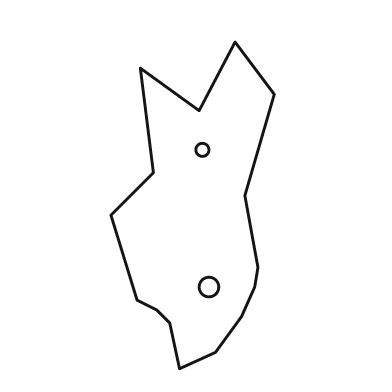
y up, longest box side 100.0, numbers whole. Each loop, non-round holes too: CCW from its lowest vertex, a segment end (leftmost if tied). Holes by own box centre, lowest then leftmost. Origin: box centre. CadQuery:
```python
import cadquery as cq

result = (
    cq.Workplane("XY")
    .moveTo(-4.0, -50.0)
    .lineTo(7.0, -45.0)
    .lineTo(15.0, -34.0)
    .lineTo(19.0, -25.0)
    .lineTo(20.0, -19.0)
    .lineTo(16.0, 3.0)
    .lineTo(25.0, 34.0)
    .lineTo(13.0, 50.0)
    .lineTo(2.0, 29.0)
    .lineTo(-16.0, 42.0)
    .lineTo(-12.0, 10.0)
    .lineTo(-25.0, -3.0)
    .lineTo(-17.0, -29.0)
    .lineTo(-11.0, -32.0)
    .lineTo(-7.0, -36.0)
    .close()
    .moveTo(5.0, -25.0)
    .circle(3.0)
    .moveTo(3.0, 17.0)
    .circle(2.0)
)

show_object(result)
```